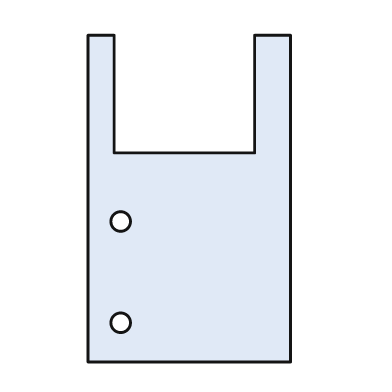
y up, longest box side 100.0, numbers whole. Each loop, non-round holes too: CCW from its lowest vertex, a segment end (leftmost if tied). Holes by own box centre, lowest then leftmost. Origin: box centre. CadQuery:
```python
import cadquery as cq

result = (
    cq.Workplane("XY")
    .moveTo(-31.0, -50.0)
    .lineTo(31.0, -50.0)
    .lineTo(31.0, 50.0)
    .lineTo(20.0, 50.0)
    .lineTo(20.0, 14.0)
    .lineTo(-23.0, 14.0)
    .lineTo(-23.0, 50.0)
    .lineTo(-31.0, 50.0)
    .close()
    .moveTo(-21.0, -38.0)
    .circle(3.0)
    .moveTo(-21.0, -7.0)
    .circle(3.0)
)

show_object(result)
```